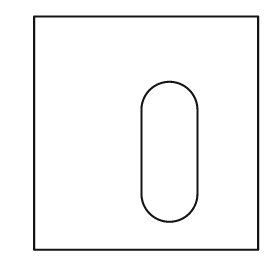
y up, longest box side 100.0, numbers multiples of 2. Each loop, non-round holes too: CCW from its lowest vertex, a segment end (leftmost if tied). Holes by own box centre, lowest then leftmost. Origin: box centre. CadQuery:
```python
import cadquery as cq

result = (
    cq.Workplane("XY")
    .moveTo(-48.0, -50.0)
    .lineTo(48.0, -50.0)
    .lineTo(48.0, 50.0)
    .lineTo(-48.0, 50.0)
    .close()
    .moveTo(-2.0, -26.0)
    .threePointArc((10.0, -38.0), (22.0, -26.0))
    .lineTo(22.0, 10.0)
    .threePointArc((10.0, 22.0), (-2.0, 10.0))
    .close()
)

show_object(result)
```